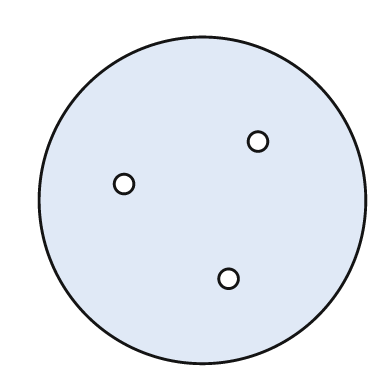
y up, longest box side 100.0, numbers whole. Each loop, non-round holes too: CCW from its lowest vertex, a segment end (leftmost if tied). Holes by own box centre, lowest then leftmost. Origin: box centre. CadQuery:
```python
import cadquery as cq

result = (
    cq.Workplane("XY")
    .moveTo(0.0, 0.0)
    .circle(50.0)
    .moveTo(8.0, -24.0)
    .circle(3.0)
    .moveTo(-24.0, 5.0)
    .circle(3.0)
    .moveTo(17.0, 18.0)
    .circle(3.0)
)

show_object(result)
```